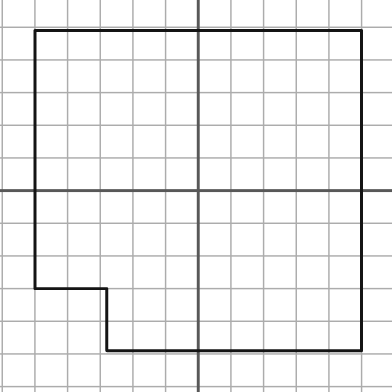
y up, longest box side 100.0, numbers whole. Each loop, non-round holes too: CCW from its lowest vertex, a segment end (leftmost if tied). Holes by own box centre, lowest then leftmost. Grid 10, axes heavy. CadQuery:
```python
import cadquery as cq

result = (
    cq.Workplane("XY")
    .moveTo(-28.0, -49.0)
    .lineTo(50.0, -49.0)
    .lineTo(50.0, 49.0)
    .lineTo(-50.0, 49.0)
    .lineTo(-50.0, -30.0)
    .lineTo(-28.0, -30.0)
    .close()
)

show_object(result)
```